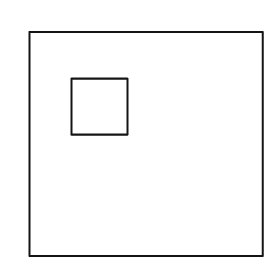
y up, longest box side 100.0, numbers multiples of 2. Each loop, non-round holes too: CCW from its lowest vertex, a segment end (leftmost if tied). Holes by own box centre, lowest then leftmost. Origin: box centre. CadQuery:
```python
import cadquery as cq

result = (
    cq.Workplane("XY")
    .moveTo(-50.0, -48.0)
    .lineTo(50.0, -48.0)
    .lineTo(50.0, 48.0)
    .lineTo(-50.0, 48.0)
    .close()
    .moveTo(-32.0, 4.0)
    .lineTo(-8.0, 4.0)
    .lineTo(-8.0, 28.0)
    .lineTo(-32.0, 28.0)
    .close()
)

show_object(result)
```